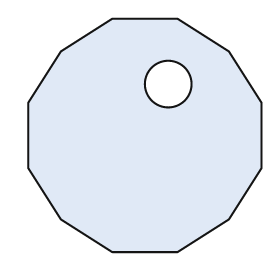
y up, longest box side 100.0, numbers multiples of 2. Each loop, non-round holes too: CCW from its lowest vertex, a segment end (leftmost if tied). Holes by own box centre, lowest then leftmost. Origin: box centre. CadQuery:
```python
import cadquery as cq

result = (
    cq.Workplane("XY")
    .moveTo(-14.0, -50.0)
    .lineTo(14.0, -50.0)
    .lineTo(36.0, -36.0)
    .lineTo(50.0, -14.0)
    .lineTo(50.0, 14.0)
    .lineTo(36.0, 36.0)
    .lineTo(14.0, 50.0)
    .lineTo(-14.0, 50.0)
    .lineTo(-36.0, 36.0)
    .lineTo(-50.0, 14.0)
    .lineTo(-50.0, -14.0)
    .lineTo(-36.0, -36.0)
    .close()
    .moveTo(10.0, 22.0)
    .circle(10.0)
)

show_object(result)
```